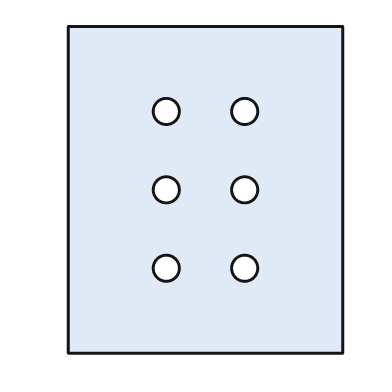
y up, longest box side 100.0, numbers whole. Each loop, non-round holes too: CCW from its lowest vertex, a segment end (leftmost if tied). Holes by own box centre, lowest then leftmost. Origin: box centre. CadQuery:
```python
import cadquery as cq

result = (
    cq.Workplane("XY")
    .moveTo(-42.0, -50.0)
    .lineTo(42.0, -50.0)
    .lineTo(42.0, 50.0)
    .lineTo(-42.0, 50.0)
    .close()
    .moveTo(-12.0, -24.0)
    .circle(4.0)
    .moveTo(12.0, -24.0)
    .circle(4.0)
    .moveTo(-12.0, 0.0)
    .circle(4.0)
    .moveTo(12.0, 0.0)
    .circle(4.0)
    .moveTo(-12.0, 24.0)
    .circle(4.0)
    .moveTo(12.0, 24.0)
    .circle(4.0)
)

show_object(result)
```